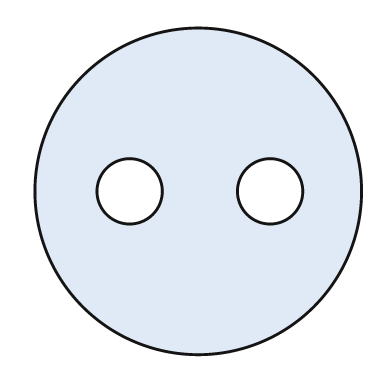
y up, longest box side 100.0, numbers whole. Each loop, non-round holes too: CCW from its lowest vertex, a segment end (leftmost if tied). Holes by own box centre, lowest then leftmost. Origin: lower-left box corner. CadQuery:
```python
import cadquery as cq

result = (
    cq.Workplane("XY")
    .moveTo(50.0, 50.0)
    .circle(50.0)
    .moveTo(29.0, 50.0)
    .circle(10.0)
    .moveTo(72.0, 50.0)
    .circle(10.0)
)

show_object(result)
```